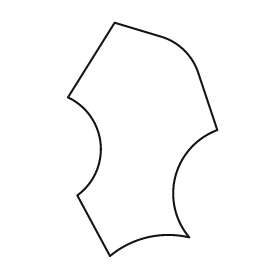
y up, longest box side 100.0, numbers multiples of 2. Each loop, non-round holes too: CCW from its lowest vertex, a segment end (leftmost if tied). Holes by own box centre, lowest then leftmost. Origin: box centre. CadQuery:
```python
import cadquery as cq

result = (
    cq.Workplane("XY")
    .moveTo(-14.0, -50.0)
    .threePointArc((2.0, -42.0), (20.0, -42.0))
    .threePointArc((14.0, -16.0), (32.0, 4.0))
    .lineTo(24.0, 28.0)
    .threePointArc((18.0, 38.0), (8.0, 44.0))
    .lineTo(-12.0, 50.0)
    .lineTo(-32.0, 18.0)
    .threePointArc((-18.0, -2.0), (-28.0, -24.0))
    .close()
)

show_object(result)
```